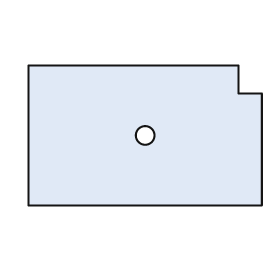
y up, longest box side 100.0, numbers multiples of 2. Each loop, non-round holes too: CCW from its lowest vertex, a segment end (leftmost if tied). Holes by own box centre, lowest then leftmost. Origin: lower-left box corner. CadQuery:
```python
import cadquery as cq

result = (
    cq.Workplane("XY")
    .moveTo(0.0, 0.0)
    .lineTo(100.0, 0.0)
    .lineTo(100.0, 48.0)
    .lineTo(90.0, 48.0)
    .lineTo(90.0, 60.0)
    .lineTo(0.0, 60.0)
    .close()
    .moveTo(50.0, 30.0)
    .circle(4.0)
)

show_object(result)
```